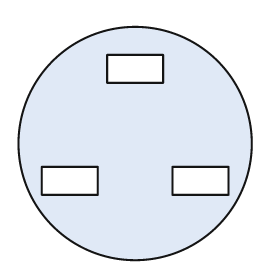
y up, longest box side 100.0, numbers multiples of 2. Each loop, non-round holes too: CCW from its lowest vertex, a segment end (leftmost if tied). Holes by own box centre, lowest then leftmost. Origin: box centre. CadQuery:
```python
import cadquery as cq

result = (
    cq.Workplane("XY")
    .moveTo(0.0, 0.0)
    .circle(50.0)
    .moveTo(-40.0, -22.0)
    .lineTo(-16.0, -22.0)
    .lineTo(-16.0, -10.0)
    .lineTo(-40.0, -10.0)
    .close()
    .moveTo(16.0, -22.0)
    .lineTo(40.0, -22.0)
    .lineTo(40.0, -10.0)
    .lineTo(16.0, -10.0)
    .close()
    .moveTo(-12.0, 26.0)
    .lineTo(12.0, 26.0)
    .lineTo(12.0, 38.0)
    .lineTo(-12.0, 38.0)
    .close()
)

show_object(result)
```